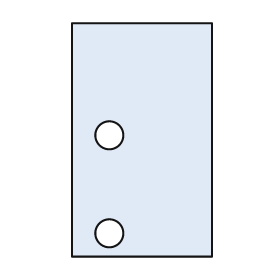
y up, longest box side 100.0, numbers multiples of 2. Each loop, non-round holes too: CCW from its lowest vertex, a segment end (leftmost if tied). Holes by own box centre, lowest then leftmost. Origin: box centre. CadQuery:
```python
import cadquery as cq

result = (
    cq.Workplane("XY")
    .moveTo(-30.0, -50.0)
    .lineTo(30.0, -50.0)
    .lineTo(30.0, 50.0)
    .lineTo(-30.0, 50.0)
    .close()
    .moveTo(-14.0, -40.0)
    .circle(6.0)
    .moveTo(-14.0, 2.0)
    .circle(6.0)
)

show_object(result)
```